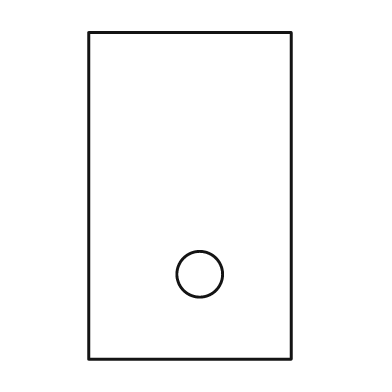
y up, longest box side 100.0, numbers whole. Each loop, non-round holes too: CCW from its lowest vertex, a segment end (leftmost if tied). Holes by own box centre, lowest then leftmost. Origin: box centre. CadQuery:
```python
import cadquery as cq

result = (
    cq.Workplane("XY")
    .moveTo(-31.0, -50.0)
    .lineTo(31.0, -50.0)
    .lineTo(31.0, 50.0)
    .lineTo(-31.0, 50.0)
    .close()
    .moveTo(3.0, -24.0)
    .circle(7.0)
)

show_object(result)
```